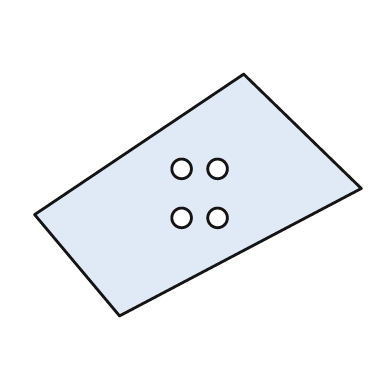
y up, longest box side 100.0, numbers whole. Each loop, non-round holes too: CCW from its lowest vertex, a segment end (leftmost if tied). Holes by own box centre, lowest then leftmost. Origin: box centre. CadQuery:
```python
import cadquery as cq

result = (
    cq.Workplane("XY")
    .moveTo(-24.0, -37.0)
    .lineTo(50.0, 2.0)
    .lineTo(14.0, 37.0)
    .lineTo(-50.0, -6.0)
    .close()
    .moveTo(-5.0, -7.0)
    .circle(3.0)
    .moveTo(6.0, -7.0)
    .circle(3.0)
    .moveTo(-5.0, 8.0)
    .circle(3.0)
    .moveTo(6.0, 8.0)
    .circle(3.0)
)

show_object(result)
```